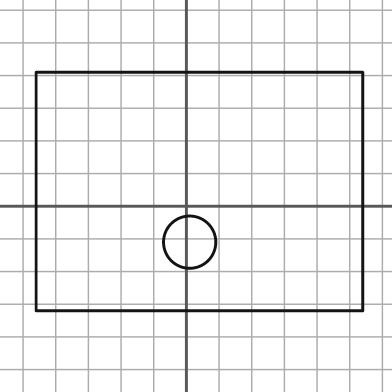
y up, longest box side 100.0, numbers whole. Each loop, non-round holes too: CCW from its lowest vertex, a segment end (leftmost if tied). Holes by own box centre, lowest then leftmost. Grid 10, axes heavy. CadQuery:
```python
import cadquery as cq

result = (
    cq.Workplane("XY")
    .moveTo(-46.0, -32.0)
    .lineTo(54.0, -32.0)
    .lineTo(54.0, 41.0)
    .lineTo(-46.0, 41.0)
    .close()
    .moveTo(1.0, -11.0)
    .circle(8.0)
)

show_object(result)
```